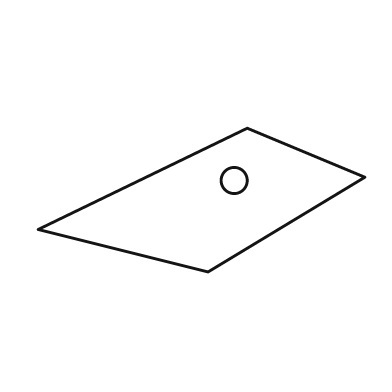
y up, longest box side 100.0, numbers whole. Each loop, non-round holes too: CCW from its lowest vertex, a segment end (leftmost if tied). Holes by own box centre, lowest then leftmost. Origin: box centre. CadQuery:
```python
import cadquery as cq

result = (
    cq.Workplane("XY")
    .moveTo(2.0, -22.0)
    .lineTo(50.0, 7.0)
    .lineTo(14.0, 22.0)
    .lineTo(-50.0, -9.0)
    .close()
    .moveTo(10.0, 6.0)
    .circle(4.0)
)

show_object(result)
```